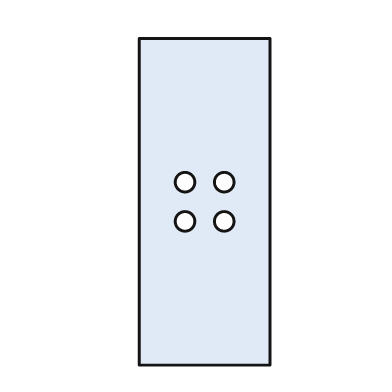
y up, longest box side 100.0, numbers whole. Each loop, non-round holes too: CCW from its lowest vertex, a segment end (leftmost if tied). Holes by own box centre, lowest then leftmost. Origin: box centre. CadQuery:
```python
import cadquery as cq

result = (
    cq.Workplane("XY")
    .moveTo(-20.0, -50.0)
    .lineTo(20.0, -50.0)
    .lineTo(20.0, 50.0)
    .lineTo(-20.0, 50.0)
    .close()
    .moveTo(-6.0, -6.0)
    .circle(3.0)
    .moveTo(6.0, -6.0)
    .circle(3.0)
    .moveTo(-6.0, 6.0)
    .circle(3.0)
    .moveTo(6.0, 6.0)
    .circle(3.0)
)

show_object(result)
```